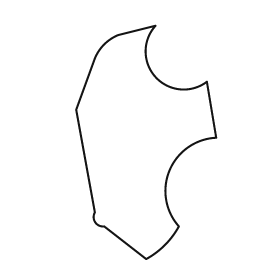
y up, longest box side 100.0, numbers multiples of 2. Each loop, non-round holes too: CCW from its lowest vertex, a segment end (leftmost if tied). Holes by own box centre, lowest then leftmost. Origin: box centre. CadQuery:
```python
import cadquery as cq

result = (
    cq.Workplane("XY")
    .moveTo(0.0, -50.0)
    .threePointArc((8.0, -44.0), (14.0, -36.0))
    .threePointArc((10.0, -12.0), (30.0, 2.0))
    .lineTo(26.0, 26.0)
    .threePointArc((4.0, 28.0), (4.0, 50.0))
    .lineTo(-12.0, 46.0)
    .threePointArc((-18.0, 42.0), (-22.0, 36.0))
    .lineTo(-30.0, 14.0)
    .lineTo(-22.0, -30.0)
    .threePointArc((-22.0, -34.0), (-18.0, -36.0))
    .close()
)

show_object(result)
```